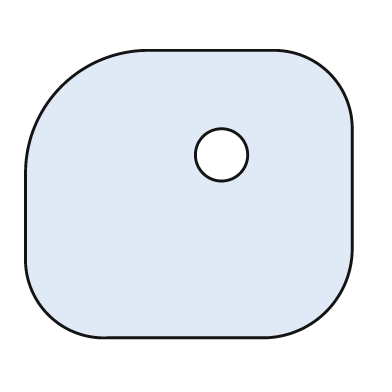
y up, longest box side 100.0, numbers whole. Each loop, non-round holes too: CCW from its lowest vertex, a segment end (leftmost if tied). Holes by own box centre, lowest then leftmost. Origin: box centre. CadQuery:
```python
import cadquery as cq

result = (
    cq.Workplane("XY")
    .moveTo(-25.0, -44.0)
    .lineTo(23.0, -44.0)
    .threePointArc((42.0, -36.0), (50.0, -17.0))
    .lineTo(50.0, 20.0)
    .threePointArc((43.0, 37.0), (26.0, 44.0))
    .lineTo(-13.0, 44.0)
    .threePointArc((-39.0, 33.0), (-50.0, 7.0))
    .lineTo(-50.0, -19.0)
    .threePointArc((-43.0, -37.0), (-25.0, -44.0))
    .close()
    .moveTo(10.0, 12.0)
    .circle(8.0)
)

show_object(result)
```